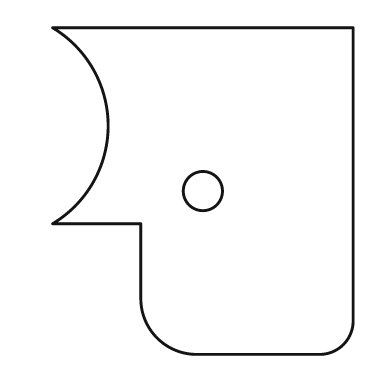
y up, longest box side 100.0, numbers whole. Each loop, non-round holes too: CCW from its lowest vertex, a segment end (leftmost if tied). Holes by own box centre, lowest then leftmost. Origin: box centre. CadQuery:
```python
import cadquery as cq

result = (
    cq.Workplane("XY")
    .moveTo(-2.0, -50.0)
    .lineTo(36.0, -50.0)
    .threePointArc((43.0, -47.0), (46.0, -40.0))
    .lineTo(46.0, 50.0)
    .lineTo(-46.0, 50.0)
    .threePointArc((-29.0, 20.0), (-46.0, -10.0))
    .lineTo(-19.0, -10.0)
    .lineTo(-19.0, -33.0)
    .threePointArc((-14.0, -45.0), (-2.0, -50.0))
    .close()
    .moveTo(0.0, 0.0)
    .circle(6.0)
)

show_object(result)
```